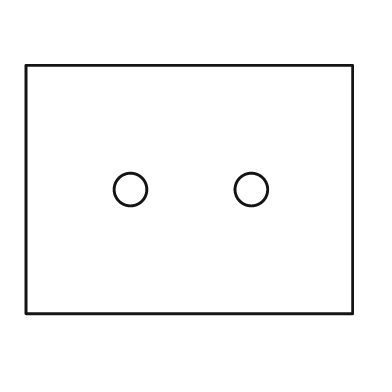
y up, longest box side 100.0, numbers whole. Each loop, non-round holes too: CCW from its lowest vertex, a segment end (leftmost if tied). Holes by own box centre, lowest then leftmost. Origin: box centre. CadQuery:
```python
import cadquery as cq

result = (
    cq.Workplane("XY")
    .moveTo(-50.0, -38.0)
    .lineTo(50.0, -38.0)
    .lineTo(50.0, 38.0)
    .lineTo(-50.0, 38.0)
    .close()
    .moveTo(-18.0, 0.0)
    .circle(5.0)
    .moveTo(19.0, 0.0)
    .circle(5.0)
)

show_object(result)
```